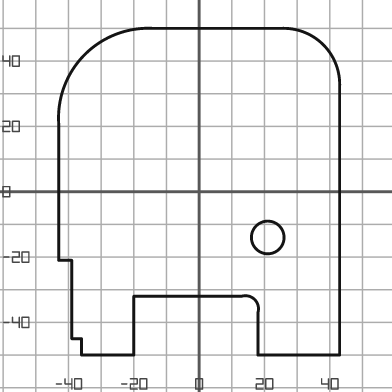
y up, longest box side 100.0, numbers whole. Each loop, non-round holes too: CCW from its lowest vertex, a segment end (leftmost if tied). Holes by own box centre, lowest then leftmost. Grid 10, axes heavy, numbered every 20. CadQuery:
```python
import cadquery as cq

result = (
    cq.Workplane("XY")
    .moveTo(-36.0, -50.0)
    .lineTo(-20.0, -50.0)
    .lineTo(-20.0, -32.0)
    .lineTo(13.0, -32.0)
    .threePointArc((17.0, -33.0), (18.0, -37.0))
    .lineTo(18.0, -50.0)
    .lineTo(43.0, -50.0)
    .lineTo(43.0, 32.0)
    .threePointArc((38.0, 45.0), (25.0, 50.0))
    .lineTo(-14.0, 50.0)
    .threePointArc((-35.0, 42.0), (-43.0, 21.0))
    .lineTo(-43.0, -21.0)
    .lineTo(-39.0, -21.0)
    .lineTo(-39.0, -45.0)
    .lineTo(-36.0, -45.0)
    .close()
    .moveTo(21.0, -14.0)
    .circle(5.0)
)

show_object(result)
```